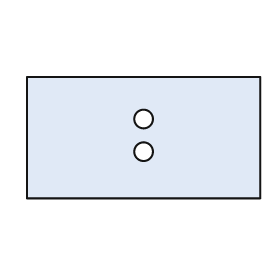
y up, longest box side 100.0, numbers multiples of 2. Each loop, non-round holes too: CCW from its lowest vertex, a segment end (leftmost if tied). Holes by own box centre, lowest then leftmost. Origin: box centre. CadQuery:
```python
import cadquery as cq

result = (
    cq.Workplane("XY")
    .moveTo(-50.0, -26.0)
    .lineTo(50.0, -26.0)
    .lineTo(50.0, 26.0)
    .lineTo(-50.0, 26.0)
    .close()
    .moveTo(0.0, -6.0)
    .circle(4.0)
    .moveTo(0.0, 8.0)
    .circle(4.0)
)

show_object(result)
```